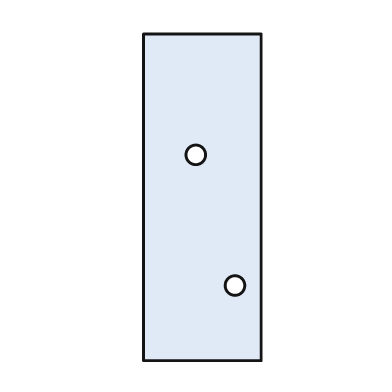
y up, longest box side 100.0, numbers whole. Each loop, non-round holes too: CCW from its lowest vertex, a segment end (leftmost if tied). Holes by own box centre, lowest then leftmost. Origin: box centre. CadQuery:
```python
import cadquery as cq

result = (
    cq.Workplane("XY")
    .moveTo(-18.0, -50.0)
    .lineTo(18.0, -50.0)
    .lineTo(18.0, 50.0)
    .lineTo(-18.0, 50.0)
    .close()
    .moveTo(10.0, -27.0)
    .circle(3.0)
    .moveTo(-2.0, 13.0)
    .circle(3.0)
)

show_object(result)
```